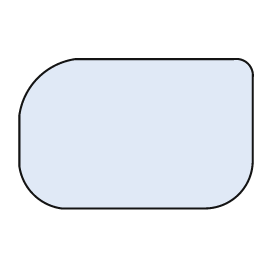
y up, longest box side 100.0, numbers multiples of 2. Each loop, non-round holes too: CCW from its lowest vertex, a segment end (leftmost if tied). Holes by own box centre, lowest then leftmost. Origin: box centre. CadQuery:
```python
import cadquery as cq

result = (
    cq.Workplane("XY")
    .moveTo(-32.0, -32.0)
    .lineTo(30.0, -32.0)
    .threePointArc((44.0, -26.0), (50.0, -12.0))
    .lineTo(50.0, 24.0)
    .threePointArc((48.0, 30.0), (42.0, 32.0))
    .lineTo(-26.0, 32.0)
    .threePointArc((-42.0, 24.0), (-50.0, 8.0))
    .lineTo(-50.0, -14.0)
    .threePointArc((-44.0, -26.0), (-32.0, -32.0))
    .close()
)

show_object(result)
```